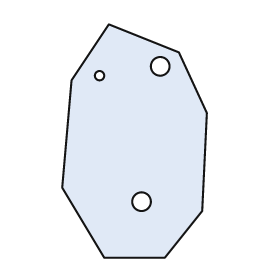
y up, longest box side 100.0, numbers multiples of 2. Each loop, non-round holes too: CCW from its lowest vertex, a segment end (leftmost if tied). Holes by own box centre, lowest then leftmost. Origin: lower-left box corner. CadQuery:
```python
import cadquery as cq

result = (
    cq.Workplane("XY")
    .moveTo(18.0, 0.0)
    .lineTo(44.0, 0.0)
    .lineTo(60.0, 20.0)
    .lineTo(62.0, 62.0)
    .lineTo(50.0, 88.0)
    .lineTo(20.0, 100.0)
    .lineTo(4.0, 76.0)
    .lineTo(0.0, 30.0)
    .close()
    .moveTo(34.0, 24.0)
    .circle(4.0)
    .moveTo(16.0, 78.0)
    .circle(2.0)
    .moveTo(42.0, 82.0)
    .circle(4.0)
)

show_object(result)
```